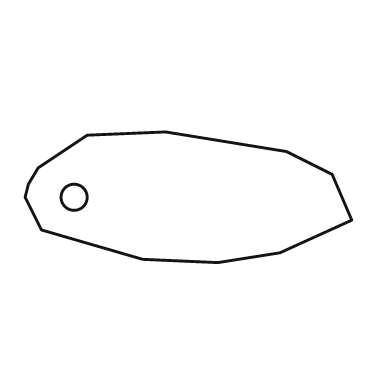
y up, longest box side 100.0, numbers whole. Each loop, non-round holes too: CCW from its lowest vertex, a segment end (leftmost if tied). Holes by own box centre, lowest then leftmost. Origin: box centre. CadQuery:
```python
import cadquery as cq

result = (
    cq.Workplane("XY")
    .moveTo(9.0, -20.0)
    .lineTo(28.0, -17.0)
    .lineTo(50.0, -7.0)
    .lineTo(44.0, 7.0)
    .lineTo(30.0, 14.0)
    .lineTo(-7.0, 20.0)
    .lineTo(-31.0, 19.0)
    .lineTo(-46.0, 9.0)
    .lineTo(-49.0, 4.0)
    .lineTo(-50.0, 0.0)
    .lineTo(-45.0, -10.0)
    .lineTo(-14.0, -19.0)
    .close()
    .moveTo(-35.0, 0.0)
    .circle(4.0)
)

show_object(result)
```